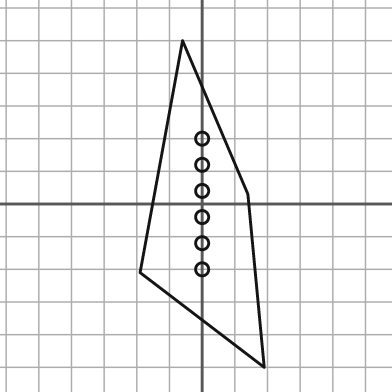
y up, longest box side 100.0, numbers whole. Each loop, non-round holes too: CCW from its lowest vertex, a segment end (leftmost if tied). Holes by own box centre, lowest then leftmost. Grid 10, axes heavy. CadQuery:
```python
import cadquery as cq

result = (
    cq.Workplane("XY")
    .moveTo(19.0, -50.0)
    .lineTo(14.0, 3.0)
    .lineTo(-6.0, 50.0)
    .lineTo(-19.0, -21.0)
    .close()
    .moveTo(0.0, -20.0)
    .circle(2.0)
    .moveTo(0.0, -12.0)
    .circle(2.0)
    .moveTo(0.0, -4.0)
    .circle(2.0)
    .moveTo(0.0, 4.0)
    .circle(2.0)
    .moveTo(0.0, 12.0)
    .circle(2.0)
    .moveTo(0.0, 20.0)
    .circle(2.0)
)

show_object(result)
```